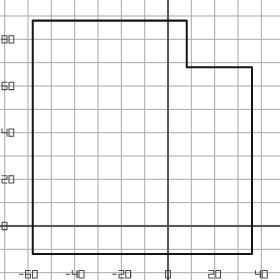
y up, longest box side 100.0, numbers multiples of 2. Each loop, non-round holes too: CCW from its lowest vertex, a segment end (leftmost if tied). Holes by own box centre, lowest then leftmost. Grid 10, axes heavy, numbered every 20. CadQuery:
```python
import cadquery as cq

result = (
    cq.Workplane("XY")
    .moveTo(-58.0, -12.0)
    .lineTo(36.0, -12.0)
    .lineTo(36.0, 68.0)
    .lineTo(8.0, 68.0)
    .lineTo(8.0, 88.0)
    .lineTo(-58.0, 88.0)
    .close()
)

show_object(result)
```